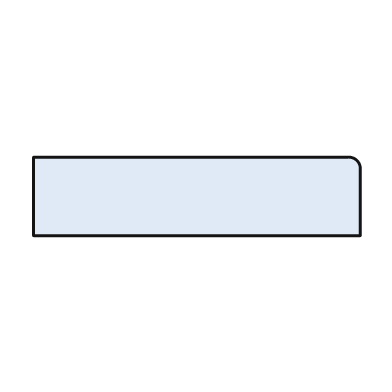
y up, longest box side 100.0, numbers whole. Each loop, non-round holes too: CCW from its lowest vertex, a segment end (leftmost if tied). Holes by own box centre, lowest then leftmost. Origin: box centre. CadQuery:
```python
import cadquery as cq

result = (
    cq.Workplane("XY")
    .moveTo(-50.0, -12.0)
    .lineTo(50.0, -12.0)
    .lineTo(50.0, 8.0)
    .threePointArc((49.0, 11.0), (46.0, 12.0))
    .lineTo(-50.0, 12.0)
    .close()
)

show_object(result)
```